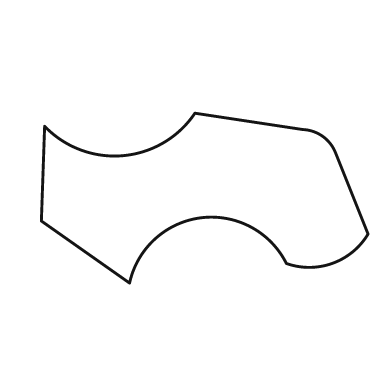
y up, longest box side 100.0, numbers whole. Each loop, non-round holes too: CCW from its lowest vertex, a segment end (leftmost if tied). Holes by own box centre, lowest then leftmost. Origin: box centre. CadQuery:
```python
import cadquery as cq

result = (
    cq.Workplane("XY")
    .moveTo(-23.0, -26.0)
    .threePointArc((-1.0, -6.0), (25.0, -20.0))
    .threePointArc((39.0, -20.0), (50.0, -11.0))
    .lineTo(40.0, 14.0)
    .threePointArc((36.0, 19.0), (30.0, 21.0))
    .lineTo(-3.0, 26.0)
    .threePointArc((-25.0, 13.0), (-49.0, 22.0))
    .lineTo(-50.0, -7.0)
    .close()
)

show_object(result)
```